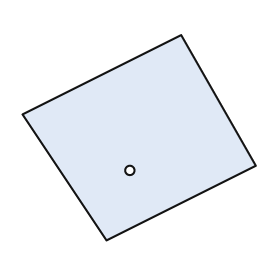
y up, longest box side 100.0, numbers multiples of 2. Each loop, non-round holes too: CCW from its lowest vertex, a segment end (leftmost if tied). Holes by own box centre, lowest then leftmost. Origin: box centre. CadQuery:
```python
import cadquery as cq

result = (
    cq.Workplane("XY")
    .moveTo(-14.0, -44.0)
    .lineTo(50.0, -12.0)
    .lineTo(18.0, 44.0)
    .lineTo(-50.0, 10.0)
    .close()
    .moveTo(-4.0, -14.0)
    .circle(2.0)
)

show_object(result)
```